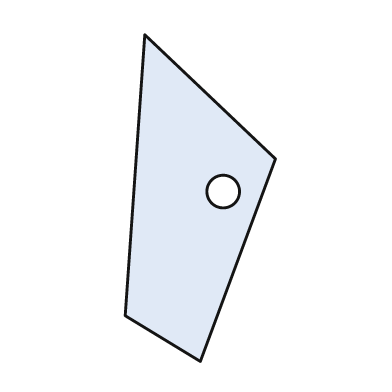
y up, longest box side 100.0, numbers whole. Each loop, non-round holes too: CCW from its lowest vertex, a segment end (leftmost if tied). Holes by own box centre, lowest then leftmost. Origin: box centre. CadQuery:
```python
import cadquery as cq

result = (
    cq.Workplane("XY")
    .moveTo(0.0, -50.0)
    .lineTo(23.0, 12.0)
    .lineTo(-17.0, 50.0)
    .lineTo(-23.0, -36.0)
    .close()
    .moveTo(7.0, 2.0)
    .circle(5.0)
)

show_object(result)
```